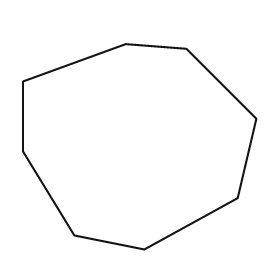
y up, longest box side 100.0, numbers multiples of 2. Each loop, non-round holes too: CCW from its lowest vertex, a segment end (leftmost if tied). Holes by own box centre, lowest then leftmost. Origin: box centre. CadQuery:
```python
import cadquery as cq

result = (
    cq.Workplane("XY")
    .moveTo(2.0, -44.0)
    .lineTo(42.0, -22.0)
    .lineTo(50.0, 12.0)
    .lineTo(20.0, 42.0)
    .lineTo(-6.0, 44.0)
    .lineTo(-50.0, 28.0)
    .lineTo(-50.0, -2.0)
    .lineTo(-28.0, -38.0)
    .close()
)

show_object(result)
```